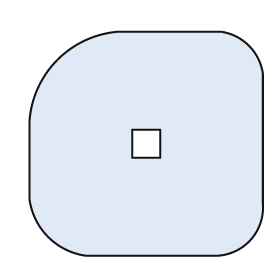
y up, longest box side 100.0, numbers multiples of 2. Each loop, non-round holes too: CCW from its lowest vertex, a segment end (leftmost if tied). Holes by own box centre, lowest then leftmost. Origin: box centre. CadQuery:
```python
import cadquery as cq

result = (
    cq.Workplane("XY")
    .moveTo(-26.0, -48.0)
    .lineTo(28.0, -48.0)
    .threePointArc((44.0, -42.0), (50.0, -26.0))
    .lineTo(50.0, 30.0)
    .threePointArc((44.0, 42.0), (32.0, 48.0))
    .lineTo(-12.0, 48.0)
    .threePointArc((-38.0, 36.0), (-50.0, 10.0))
    .lineTo(-50.0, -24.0)
    .threePointArc((-42.0, -40.0), (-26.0, -48.0))
    .close()
    .moveTo(-6.0, -6.0)
    .lineTo(6.0, -6.0)
    .lineTo(6.0, 6.0)
    .lineTo(-6.0, 6.0)
    .close()
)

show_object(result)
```